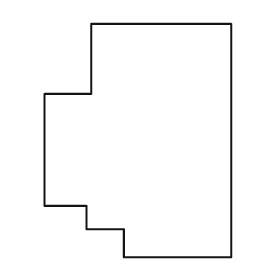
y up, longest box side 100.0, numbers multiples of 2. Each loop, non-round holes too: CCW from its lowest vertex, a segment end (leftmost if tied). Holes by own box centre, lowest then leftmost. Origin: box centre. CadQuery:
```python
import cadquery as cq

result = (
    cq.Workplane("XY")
    .moveTo(-6.0, -50.0)
    .lineTo(40.0, -50.0)
    .lineTo(40.0, 50.0)
    .lineTo(-20.0, 50.0)
    .lineTo(-20.0, 20.0)
    .lineTo(-40.0, 20.0)
    .lineTo(-40.0, -28.0)
    .lineTo(-22.0, -28.0)
    .lineTo(-22.0, -38.0)
    .lineTo(-6.0, -38.0)
    .close()
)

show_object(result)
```